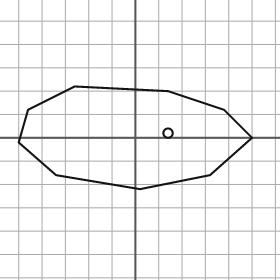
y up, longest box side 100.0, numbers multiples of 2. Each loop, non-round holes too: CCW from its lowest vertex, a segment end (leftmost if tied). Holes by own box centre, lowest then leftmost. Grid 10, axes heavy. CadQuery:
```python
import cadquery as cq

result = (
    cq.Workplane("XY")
    .moveTo(2.0, -22.0)
    .lineTo(32.0, -16.0)
    .lineTo(50.0, 0.0)
    .lineTo(38.0, 12.0)
    .lineTo(14.0, 20.0)
    .lineTo(-26.0, 22.0)
    .lineTo(-46.0, 12.0)
    .lineTo(-50.0, -2.0)
    .lineTo(-34.0, -16.0)
    .close()
    .moveTo(14.0, 2.0)
    .circle(2.0)
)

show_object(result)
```